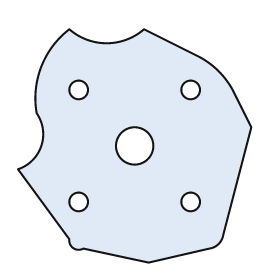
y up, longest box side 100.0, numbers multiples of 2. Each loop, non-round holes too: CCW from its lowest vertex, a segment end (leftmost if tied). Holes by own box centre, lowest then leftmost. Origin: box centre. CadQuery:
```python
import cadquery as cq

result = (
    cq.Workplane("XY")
    .moveTo(6.0, -50.0)
    .lineTo(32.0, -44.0)
    .threePointArc((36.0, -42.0), (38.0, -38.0))
    .lineTo(50.0, 8.0)
    .lineTo(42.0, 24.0)
    .threePointArc((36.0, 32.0), (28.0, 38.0))
    .lineTo(4.0, 50.0)
    .threePointArc((-12.0, 44.0), (-28.0, 50.0))
    .threePointArc((-40.0, 34.0), (-42.0, 14.0))
    .threePointArc((-40.0, 0.0), (-50.0, -10.0))
    .lineTo(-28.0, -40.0)
    .threePointArc((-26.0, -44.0), (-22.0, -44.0))
    .close()
    .moveTo(-24.0, -24.0)
    .circle(4.0)
    .moveTo(24.0, -24.0)
    .circle(4.0)
    .moveTo(0.0, 0.0)
    .circle(8.0)
    .moveTo(-24.0, 24.0)
    .circle(4.0)
    .moveTo(24.0, 24.0)
    .circle(4.0)
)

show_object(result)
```